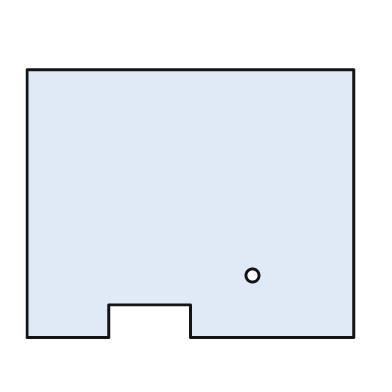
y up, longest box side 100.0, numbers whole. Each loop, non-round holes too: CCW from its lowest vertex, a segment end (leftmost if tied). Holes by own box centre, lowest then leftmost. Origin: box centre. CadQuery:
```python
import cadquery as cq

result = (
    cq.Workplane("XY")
    .moveTo(-50.0, -41.0)
    .lineTo(-25.0, -41.0)
    .lineTo(-25.0, -31.0)
    .lineTo(0.0, -31.0)
    .lineTo(0.0, -41.0)
    .lineTo(50.0, -41.0)
    .lineTo(50.0, 41.0)
    .lineTo(-50.0, 41.0)
    .close()
    .moveTo(19.0, -22.0)
    .circle(2.0)
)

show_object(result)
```